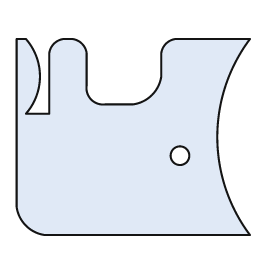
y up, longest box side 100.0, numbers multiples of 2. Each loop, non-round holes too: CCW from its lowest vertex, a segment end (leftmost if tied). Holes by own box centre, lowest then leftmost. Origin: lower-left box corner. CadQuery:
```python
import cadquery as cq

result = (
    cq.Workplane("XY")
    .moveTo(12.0, 0.0)
    .lineTo(100.0, 0.0)
    .threePointArc((86.0, 42.0), (100.0, 84.0))
    .lineTo(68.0, 84.0)
    .threePointArc((64.0, 82.0), (62.0, 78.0))
    .lineTo(62.0, 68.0)
    .threePointArc((58.0, 60.0), (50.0, 56.0))
    .lineTo(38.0, 56.0)
    .threePointArc((32.0, 58.0), (30.0, 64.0))
    .lineTo(30.0, 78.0)
    .threePointArc((28.0, 82.0), (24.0, 84.0))
    .lineTo(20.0, 84.0)
    .threePointArc((16.0, 82.0), (14.0, 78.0))
    .lineTo(14.0, 52.0)
    .lineTo(4.0, 52.0)
    .threePointArc((10.0, 68.0), (4.0, 84.0))
    .lineTo(0.0, 84.0)
    .lineTo(0.0, 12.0)
    .threePointArc((4.0, 4.0), (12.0, 0.0))
    .close()
    .moveTo(70.0, 34.0)
    .circle(4.0)
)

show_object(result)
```